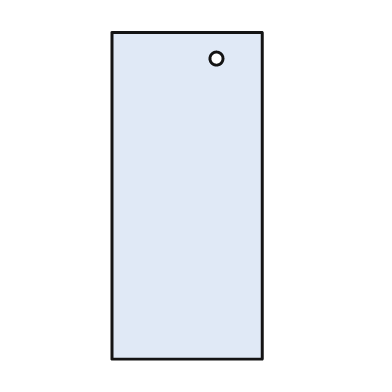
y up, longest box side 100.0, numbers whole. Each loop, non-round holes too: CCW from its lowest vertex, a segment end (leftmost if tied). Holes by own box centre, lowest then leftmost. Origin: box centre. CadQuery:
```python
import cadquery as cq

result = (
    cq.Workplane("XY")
    .moveTo(-23.0, -50.0)
    .lineTo(23.0, -50.0)
    .lineTo(23.0, 50.0)
    .lineTo(-23.0, 50.0)
    .close()
    .moveTo(9.0, 42.0)
    .circle(2.0)
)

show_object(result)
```